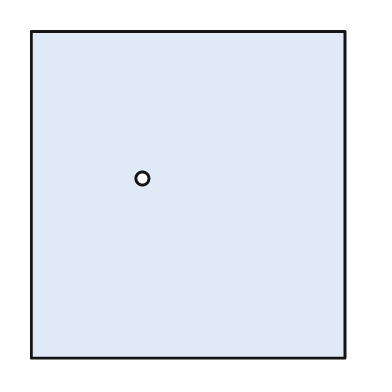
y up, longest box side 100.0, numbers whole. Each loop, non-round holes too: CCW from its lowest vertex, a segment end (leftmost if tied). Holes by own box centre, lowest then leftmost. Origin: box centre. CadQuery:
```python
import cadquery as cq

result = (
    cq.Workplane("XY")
    .moveTo(-48.0, -50.0)
    .lineTo(48.0, -50.0)
    .lineTo(48.0, 50.0)
    .lineTo(-48.0, 50.0)
    .close()
    .moveTo(-14.0, 5.0)
    .circle(2.0)
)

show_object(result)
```